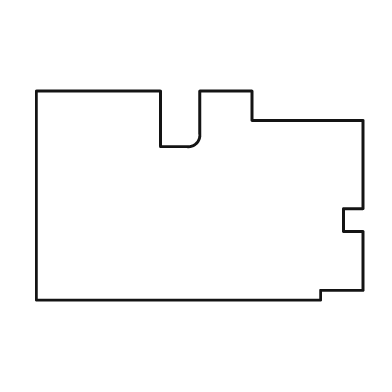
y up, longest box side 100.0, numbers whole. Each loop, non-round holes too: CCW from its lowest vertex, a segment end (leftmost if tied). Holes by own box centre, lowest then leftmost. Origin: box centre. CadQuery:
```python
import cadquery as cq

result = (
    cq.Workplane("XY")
    .moveTo(-50.0, -32.0)
    .lineTo(37.0, -32.0)
    .lineTo(37.0, -29.0)
    .lineTo(50.0, -29.0)
    .lineTo(50.0, -11.0)
    .lineTo(44.0, -11.0)
    .lineTo(44.0, -4.0)
    .lineTo(50.0, -4.0)
    .lineTo(50.0, 23.0)
    .lineTo(16.0, 23.0)
    .lineTo(16.0, 32.0)
    .lineTo(0.0, 32.0)
    .lineTo(0.0, 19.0)
    .threePointArc((-1.0, 16.0), (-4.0, 15.0))
    .lineTo(-12.0, 15.0)
    .lineTo(-12.0, 32.0)
    .lineTo(-50.0, 32.0)
    .close()
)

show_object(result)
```